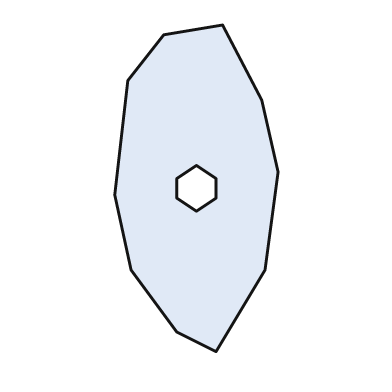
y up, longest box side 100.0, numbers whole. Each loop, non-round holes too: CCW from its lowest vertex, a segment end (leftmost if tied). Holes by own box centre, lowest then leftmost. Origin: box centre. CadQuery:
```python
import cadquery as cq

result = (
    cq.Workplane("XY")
    .moveTo(6.0, -50.0)
    .lineTo(21.0, -25.0)
    .lineTo(25.0, 5.0)
    .lineTo(20.0, 27.0)
    .lineTo(8.0, 50.0)
    .lineTo(-10.0, 47.0)
    .lineTo(-21.0, 33.0)
    .lineTo(-25.0, -2.0)
    .lineTo(-20.0, -25.0)
    .lineTo(-6.0, -44.0)
    .close()
    .moveTo(0.0, -7.0)
    .lineTo(6.0, -3.0)
    .lineTo(6.0, 3.0)
    .lineTo(0.0, 7.0)
    .lineTo(-6.0, 3.0)
    .lineTo(-6.0, -3.0)
    .close()
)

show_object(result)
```